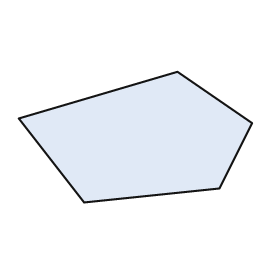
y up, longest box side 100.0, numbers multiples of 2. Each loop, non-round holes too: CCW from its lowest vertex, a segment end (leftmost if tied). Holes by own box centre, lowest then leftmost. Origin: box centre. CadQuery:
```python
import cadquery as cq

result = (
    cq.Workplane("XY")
    .moveTo(-22.0, -28.0)
    .lineTo(36.0, -22.0)
    .lineTo(50.0, 6.0)
    .lineTo(18.0, 28.0)
    .lineTo(-50.0, 8.0)
    .close()
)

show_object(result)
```